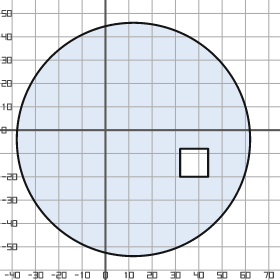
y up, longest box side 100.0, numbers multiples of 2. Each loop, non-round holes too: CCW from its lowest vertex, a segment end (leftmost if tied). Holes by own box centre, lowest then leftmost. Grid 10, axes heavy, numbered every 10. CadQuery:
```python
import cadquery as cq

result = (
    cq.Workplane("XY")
    .moveTo(12.0, -4.0)
    .circle(50.0)
    .moveTo(32.0, -20.0)
    .lineTo(44.0, -20.0)
    .lineTo(44.0, -8.0)
    .lineTo(32.0, -8.0)
    .close()
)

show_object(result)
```